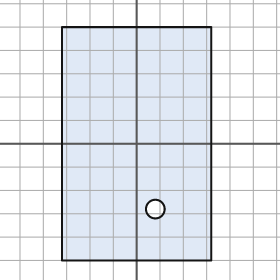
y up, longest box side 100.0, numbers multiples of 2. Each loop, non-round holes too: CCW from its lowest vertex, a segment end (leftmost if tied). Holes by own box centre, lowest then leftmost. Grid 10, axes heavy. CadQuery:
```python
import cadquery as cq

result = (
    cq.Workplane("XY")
    .moveTo(-32.0, -50.0)
    .lineTo(32.0, -50.0)
    .lineTo(32.0, 50.0)
    .lineTo(-32.0, 50.0)
    .close()
    .moveTo(8.0, -28.0)
    .circle(4.0)
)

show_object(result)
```